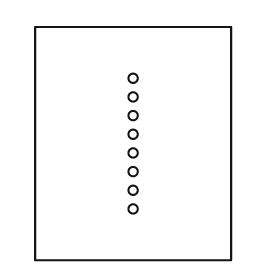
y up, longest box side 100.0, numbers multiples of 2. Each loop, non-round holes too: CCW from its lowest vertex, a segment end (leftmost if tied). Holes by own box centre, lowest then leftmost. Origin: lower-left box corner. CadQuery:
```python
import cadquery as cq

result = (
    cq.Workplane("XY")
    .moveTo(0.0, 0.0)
    .lineTo(84.0, 0.0)
    .lineTo(84.0, 100.0)
    .lineTo(0.0, 100.0)
    .close()
    .moveTo(42.0, 22.0)
    .circle(2.0)
    .moveTo(42.0, 30.0)
    .circle(2.0)
    .moveTo(42.0, 38.0)
    .circle(2.0)
    .moveTo(42.0, 46.0)
    .circle(2.0)
    .moveTo(42.0, 54.0)
    .circle(2.0)
    .moveTo(42.0, 62.0)
    .circle(2.0)
    .moveTo(42.0, 70.0)
    .circle(2.0)
    .moveTo(42.0, 78.0)
    .circle(2.0)
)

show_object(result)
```